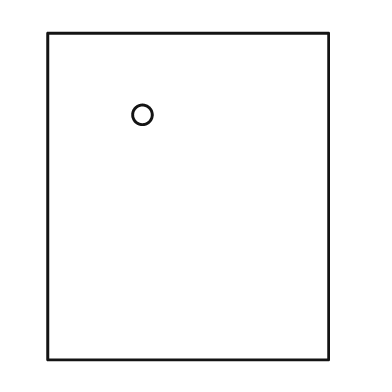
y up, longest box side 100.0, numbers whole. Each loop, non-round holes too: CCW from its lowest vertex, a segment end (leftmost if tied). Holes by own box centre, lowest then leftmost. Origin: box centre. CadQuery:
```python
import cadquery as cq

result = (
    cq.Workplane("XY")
    .moveTo(-43.0, -50.0)
    .lineTo(43.0, -50.0)
    .lineTo(43.0, 50.0)
    .lineTo(-43.0, 50.0)
    .close()
    .moveTo(-14.0, 25.0)
    .circle(3.0)
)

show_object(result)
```